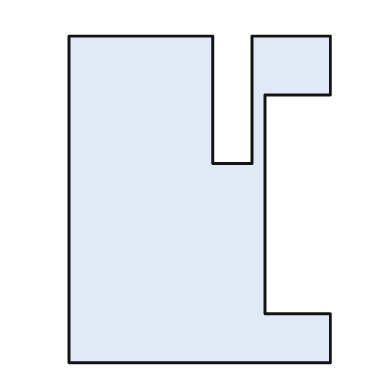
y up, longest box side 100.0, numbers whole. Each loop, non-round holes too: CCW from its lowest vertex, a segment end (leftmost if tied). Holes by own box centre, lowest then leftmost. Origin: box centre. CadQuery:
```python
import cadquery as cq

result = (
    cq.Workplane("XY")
    .moveTo(-40.0, -50.0)
    .lineTo(40.0, -50.0)
    .lineTo(40.0, -35.0)
    .lineTo(20.0, -35.0)
    .lineTo(20.0, 32.0)
    .lineTo(40.0, 32.0)
    .lineTo(40.0, 50.0)
    .lineTo(16.0, 50.0)
    .lineTo(16.0, 11.0)
    .lineTo(4.0, 11.0)
    .lineTo(4.0, 50.0)
    .lineTo(-40.0, 50.0)
    .close()
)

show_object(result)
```